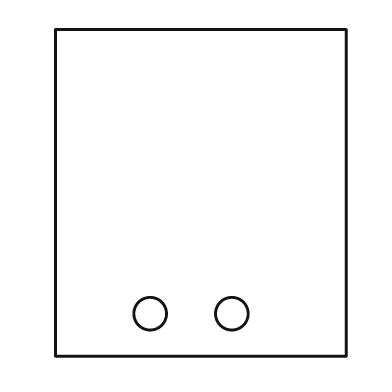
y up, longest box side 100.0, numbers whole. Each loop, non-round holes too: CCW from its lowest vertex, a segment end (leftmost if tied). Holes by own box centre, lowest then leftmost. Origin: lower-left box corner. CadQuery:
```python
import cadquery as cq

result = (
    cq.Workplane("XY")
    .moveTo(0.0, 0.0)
    .lineTo(89.0, 0.0)
    .lineTo(89.0, 100.0)
    .lineTo(0.0, 100.0)
    .close()
    .moveTo(29.0, 13.0)
    .circle(5.0)
    .moveTo(54.0, 13.0)
    .circle(5.0)
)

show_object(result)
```